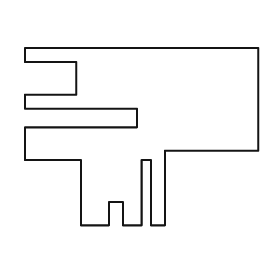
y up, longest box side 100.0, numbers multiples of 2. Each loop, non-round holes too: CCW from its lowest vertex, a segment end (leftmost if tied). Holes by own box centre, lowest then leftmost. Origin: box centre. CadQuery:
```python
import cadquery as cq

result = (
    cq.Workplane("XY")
    .moveTo(-26.0, -38.0)
    .lineTo(-14.0, -38.0)
    .lineTo(-14.0, -28.0)
    .lineTo(-8.0, -28.0)
    .lineTo(-8.0, -38.0)
    .lineTo(0.0, -38.0)
    .lineTo(0.0, -10.0)
    .lineTo(4.0, -10.0)
    .lineTo(4.0, -38.0)
    .lineTo(10.0, -38.0)
    .lineTo(10.0, -6.0)
    .lineTo(50.0, -6.0)
    .lineTo(50.0, 38.0)
    .lineTo(-50.0, 38.0)
    .lineTo(-50.0, 32.0)
    .lineTo(-28.0, 32.0)
    .lineTo(-28.0, 18.0)
    .lineTo(-50.0, 18.0)
    .lineTo(-50.0, 12.0)
    .lineTo(-2.0, 12.0)
    .lineTo(-2.0, 4.0)
    .lineTo(-50.0, 4.0)
    .lineTo(-50.0, -10.0)
    .lineTo(-26.0, -10.0)
    .close()
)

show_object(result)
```